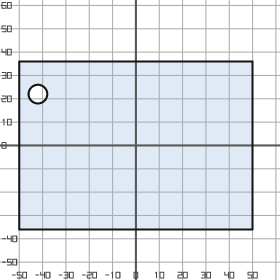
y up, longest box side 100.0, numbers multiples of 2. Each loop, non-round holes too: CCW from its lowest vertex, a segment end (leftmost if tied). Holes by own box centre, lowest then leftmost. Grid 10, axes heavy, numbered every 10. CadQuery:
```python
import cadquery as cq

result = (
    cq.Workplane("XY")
    .moveTo(-50.0, -36.0)
    .lineTo(50.0, -36.0)
    .lineTo(50.0, 36.0)
    .lineTo(-50.0, 36.0)
    .close()
    .moveTo(-42.0, 22.0)
    .circle(4.0)
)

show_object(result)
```